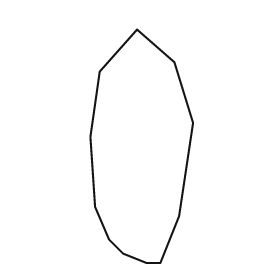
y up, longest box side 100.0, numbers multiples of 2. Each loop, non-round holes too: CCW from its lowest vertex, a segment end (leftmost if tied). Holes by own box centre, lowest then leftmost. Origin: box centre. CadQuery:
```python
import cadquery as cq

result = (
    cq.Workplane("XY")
    .moveTo(2.0, -50.0)
    .lineTo(8.0, -50.0)
    .lineTo(16.0, -30.0)
    .lineTo(22.0, 10.0)
    .lineTo(14.0, 36.0)
    .lineTo(-2.0, 50.0)
    .lineTo(-18.0, 32.0)
    .lineTo(-22.0, 4.0)
    .lineTo(-20.0, -26.0)
    .lineTo(-14.0, -40.0)
    .lineTo(-8.0, -46.0)
    .close()
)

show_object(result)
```